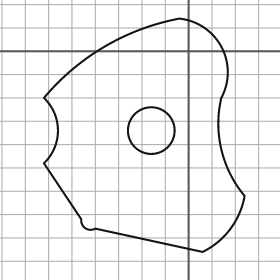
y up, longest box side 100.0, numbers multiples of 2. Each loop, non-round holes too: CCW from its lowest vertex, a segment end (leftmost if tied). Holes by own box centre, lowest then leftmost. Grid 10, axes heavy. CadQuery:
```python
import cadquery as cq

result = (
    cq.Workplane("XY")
    .moveTo(6.0, -86.0)
    .threePointArc((18.0, -76.0), (24.0, -62.0))
    .threePointArc((14.0, -42.0), (14.0, -20.0))
    .threePointArc((14.0, 2.0), (-4.0, 14.0))
    .threePointArc((-36.0, 2.0), (-62.0, -20.0))
    .threePointArc((-56.0, -34.0), (-62.0, -48.0))
    .lineTo(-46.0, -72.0)
    .threePointArc((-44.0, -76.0), (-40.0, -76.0))
    .close()
    .moveTo(-16.0, -34.0)
    .circle(10.0)
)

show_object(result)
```